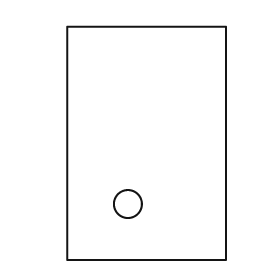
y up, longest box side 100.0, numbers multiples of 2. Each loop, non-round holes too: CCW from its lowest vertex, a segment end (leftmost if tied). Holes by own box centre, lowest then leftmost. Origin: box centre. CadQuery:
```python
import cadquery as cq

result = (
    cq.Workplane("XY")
    .moveTo(-34.0, -50.0)
    .lineTo(34.0, -50.0)
    .lineTo(34.0, 50.0)
    .lineTo(-34.0, 50.0)
    .close()
    .moveTo(-8.0, -26.0)
    .circle(6.0)
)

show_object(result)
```